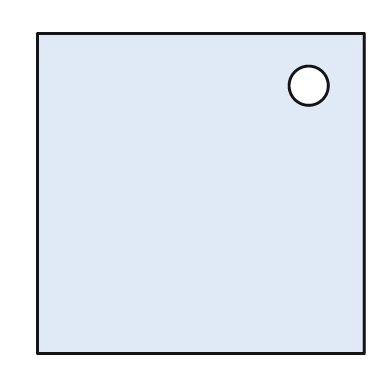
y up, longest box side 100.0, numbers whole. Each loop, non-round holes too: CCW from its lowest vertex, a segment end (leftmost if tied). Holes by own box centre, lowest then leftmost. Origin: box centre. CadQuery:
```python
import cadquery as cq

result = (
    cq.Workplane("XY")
    .moveTo(-50.0, -49.0)
    .lineTo(50.0, -49.0)
    .lineTo(50.0, 49.0)
    .lineTo(-50.0, 49.0)
    .close()
    .moveTo(33.0, 33.0)
    .circle(6.0)
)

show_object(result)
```